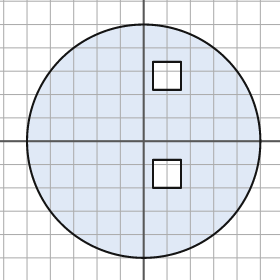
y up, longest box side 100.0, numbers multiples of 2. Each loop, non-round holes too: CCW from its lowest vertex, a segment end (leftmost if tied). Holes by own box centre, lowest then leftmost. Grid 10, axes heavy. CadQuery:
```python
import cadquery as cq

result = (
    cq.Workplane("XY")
    .moveTo(0.0, 0.0)
    .circle(50.0)
    .moveTo(4.0, -20.0)
    .lineTo(16.0, -20.0)
    .lineTo(16.0, -8.0)
    .lineTo(4.0, -8.0)
    .close()
    .moveTo(4.0, 22.0)
    .lineTo(16.0, 22.0)
    .lineTo(16.0, 34.0)
    .lineTo(4.0, 34.0)
    .close()
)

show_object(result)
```